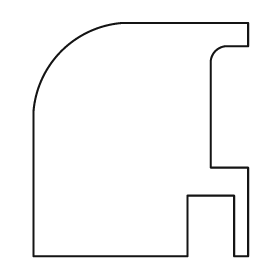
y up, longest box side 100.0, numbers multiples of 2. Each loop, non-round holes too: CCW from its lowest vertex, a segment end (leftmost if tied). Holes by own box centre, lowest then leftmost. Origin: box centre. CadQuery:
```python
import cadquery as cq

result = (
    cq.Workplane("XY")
    .moveTo(-46.0, -50.0)
    .lineTo(20.0, -50.0)
    .lineTo(20.0, -24.0)
    .lineTo(40.0, -24.0)
    .lineTo(40.0, -50.0)
    .lineTo(46.0, -50.0)
    .lineTo(46.0, -12.0)
    .lineTo(30.0, -12.0)
    .lineTo(30.0, 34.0)
    .threePointArc((32.0, 38.0), (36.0, 40.0))
    .lineTo(46.0, 40.0)
    .lineTo(46.0, 50.0)
    .lineTo(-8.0, 50.0)
    .threePointArc((-34.0, 38.0), (-46.0, 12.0))
    .close()
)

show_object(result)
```